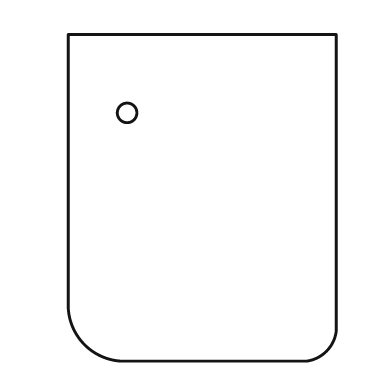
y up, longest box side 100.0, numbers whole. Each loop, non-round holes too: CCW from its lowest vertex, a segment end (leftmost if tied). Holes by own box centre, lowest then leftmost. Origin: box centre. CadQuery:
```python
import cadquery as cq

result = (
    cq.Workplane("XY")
    .moveTo(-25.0, -50.0)
    .lineTo(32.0, -50.0)
    .threePointArc((38.0, -47.0), (41.0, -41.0))
    .lineTo(41.0, 50.0)
    .lineTo(-41.0, 50.0)
    .lineTo(-41.0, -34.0)
    .threePointArc((-36.0, -45.0), (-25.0, -50.0))
    .close()
    .moveTo(-23.0, 26.0)
    .circle(3.0)
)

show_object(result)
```